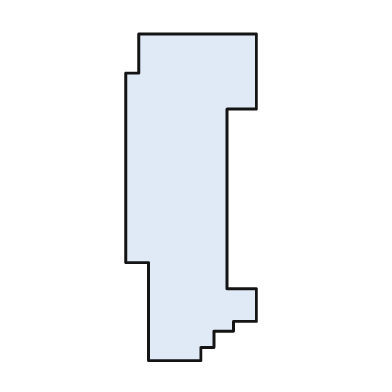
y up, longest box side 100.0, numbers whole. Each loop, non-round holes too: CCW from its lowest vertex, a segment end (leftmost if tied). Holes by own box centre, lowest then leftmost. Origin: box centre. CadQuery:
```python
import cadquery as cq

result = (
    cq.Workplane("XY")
    .moveTo(-13.0, -50.0)
    .lineTo(3.0, -50.0)
    .lineTo(3.0, -46.0)
    .lineTo(7.0, -46.0)
    .lineTo(7.0, -41.0)
    .lineTo(13.0, -41.0)
    .lineTo(13.0, -38.0)
    .lineTo(20.0, -38.0)
    .lineTo(20.0, -28.0)
    .lineTo(11.0, -28.0)
    .lineTo(11.0, 27.0)
    .lineTo(20.0, 27.0)
    .lineTo(20.0, 50.0)
    .lineTo(-16.0, 50.0)
    .lineTo(-16.0, 38.0)
    .lineTo(-20.0, 38.0)
    .lineTo(-20.0, -20.0)
    .lineTo(-13.0, -20.0)
    .close()
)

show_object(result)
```